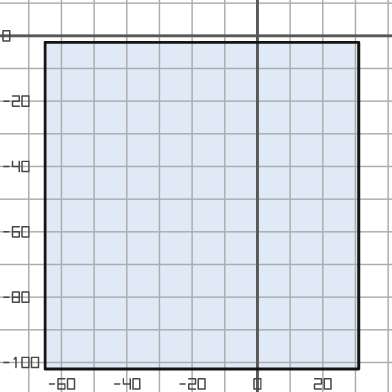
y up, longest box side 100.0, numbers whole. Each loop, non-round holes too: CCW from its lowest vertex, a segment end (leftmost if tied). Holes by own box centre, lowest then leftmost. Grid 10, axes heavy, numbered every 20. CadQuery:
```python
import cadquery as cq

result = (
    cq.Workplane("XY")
    .moveTo(-65.0, -102.0)
    .lineTo(31.0, -102.0)
    .lineTo(31.0, -2.0)
    .lineTo(-65.0, -2.0)
    .close()
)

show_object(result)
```